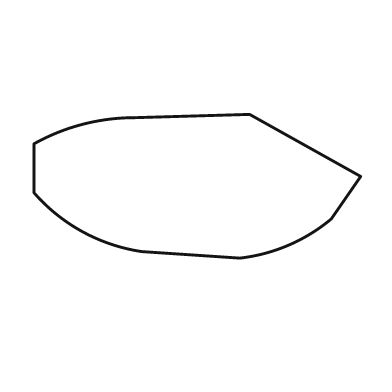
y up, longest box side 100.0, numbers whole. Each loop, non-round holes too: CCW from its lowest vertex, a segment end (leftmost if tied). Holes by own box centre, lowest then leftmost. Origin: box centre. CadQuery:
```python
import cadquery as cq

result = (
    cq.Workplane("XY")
    .moveTo(13.0, -22.0)
    .threePointArc((28.0, -18.0), (41.0, -10.0))
    .lineTo(50.0, 3.0)
    .lineTo(16.0, 22.0)
    .lineTo(-19.0, 21.0)
    .threePointArc((-35.0, 19.0), (-50.0, 13.0))
    .lineTo(-50.0, -2.0)
    .threePointArc((-35.0, -14.0), (-17.0, -20.0))
    .close()
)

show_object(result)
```